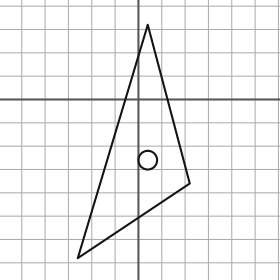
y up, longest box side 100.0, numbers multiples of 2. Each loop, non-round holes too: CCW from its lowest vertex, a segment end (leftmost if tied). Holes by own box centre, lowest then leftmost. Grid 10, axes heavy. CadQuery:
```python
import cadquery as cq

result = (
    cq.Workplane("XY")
    .moveTo(-26.0, -68.0)
    .lineTo(22.0, -36.0)
    .lineTo(4.0, 32.0)
    .close()
    .moveTo(4.0, -26.0)
    .circle(4.0)
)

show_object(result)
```